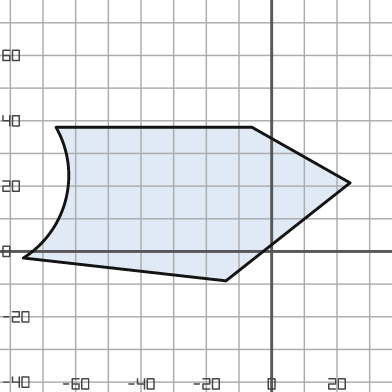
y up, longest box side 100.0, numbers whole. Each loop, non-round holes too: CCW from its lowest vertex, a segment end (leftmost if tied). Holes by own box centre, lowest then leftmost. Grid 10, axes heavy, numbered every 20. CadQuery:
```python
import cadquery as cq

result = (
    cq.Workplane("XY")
    .moveTo(-14.0, -9.0)
    .lineTo(24.0, 21.0)
    .lineTo(-6.0, 38.0)
    .lineTo(-66.0, 38.0)
    .threePointArc((-63.0, 16.0), (-76.0, -2.0))
    .close()
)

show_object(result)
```